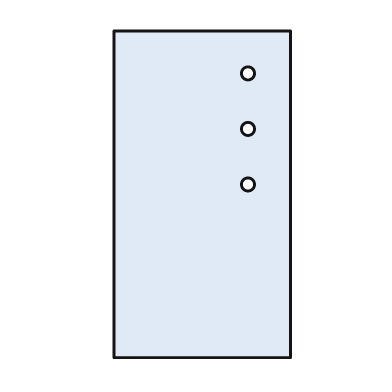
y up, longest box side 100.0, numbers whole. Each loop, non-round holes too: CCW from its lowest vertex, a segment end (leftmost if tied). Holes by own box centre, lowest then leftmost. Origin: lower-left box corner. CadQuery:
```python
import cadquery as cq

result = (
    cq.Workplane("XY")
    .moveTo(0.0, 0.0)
    .lineTo(54.0, 0.0)
    .lineTo(54.0, 100.0)
    .lineTo(0.0, 100.0)
    .close()
    .moveTo(41.0, 53.0)
    .circle(2.0)
    .moveTo(41.0, 70.0)
    .circle(2.0)
    .moveTo(41.0, 87.0)
    .circle(2.0)
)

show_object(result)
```